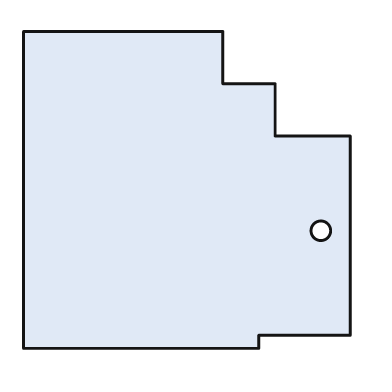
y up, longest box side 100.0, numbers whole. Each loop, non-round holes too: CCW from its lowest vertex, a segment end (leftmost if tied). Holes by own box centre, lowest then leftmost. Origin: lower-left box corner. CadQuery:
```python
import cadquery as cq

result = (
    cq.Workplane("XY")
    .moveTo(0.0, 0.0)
    .lineTo(72.0, 0.0)
    .lineTo(72.0, 4.0)
    .lineTo(100.0, 4.0)
    .lineTo(100.0, 65.0)
    .lineTo(77.0, 65.0)
    .lineTo(77.0, 81.0)
    .lineTo(61.0, 81.0)
    .lineTo(61.0, 97.0)
    .lineTo(0.0, 97.0)
    .close()
    .moveTo(91.0, 36.0)
    .circle(3.0)
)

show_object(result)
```